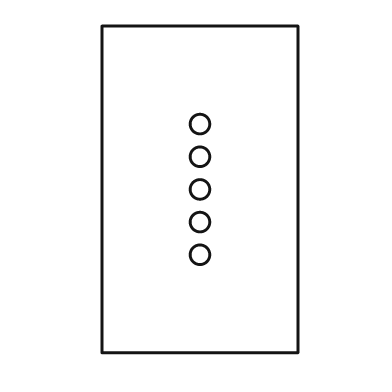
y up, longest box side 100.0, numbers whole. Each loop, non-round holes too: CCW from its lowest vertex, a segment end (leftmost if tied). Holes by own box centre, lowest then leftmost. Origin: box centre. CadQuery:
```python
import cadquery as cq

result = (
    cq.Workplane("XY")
    .moveTo(-30.0, -50.0)
    .lineTo(30.0, -50.0)
    .lineTo(30.0, 50.0)
    .lineTo(-30.0, 50.0)
    .close()
    .moveTo(0.0, -20.0)
    .circle(3.0)
    .moveTo(0.0, -10.0)
    .circle(3.0)
    .moveTo(0.0, 0.0)
    .circle(3.0)
    .moveTo(0.0, 10.0)
    .circle(3.0)
    .moveTo(0.0, 20.0)
    .circle(3.0)
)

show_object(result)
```